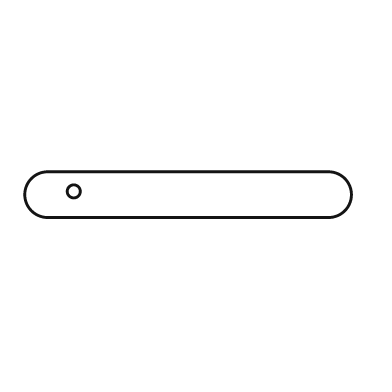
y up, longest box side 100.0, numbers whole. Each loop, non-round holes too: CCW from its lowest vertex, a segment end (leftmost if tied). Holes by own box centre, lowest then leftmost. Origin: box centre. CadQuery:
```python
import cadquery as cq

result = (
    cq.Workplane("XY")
    .moveTo(-43.0, -7.0)
    .lineTo(43.0, -7.0)
    .threePointArc((50.0, 0.0), (43.0, 7.0))
    .lineTo(-43.0, 7.0)
    .threePointArc((-50.0, 0.0), (-43.0, -7.0))
    .close()
    .moveTo(-35.0, 1.0)
    .circle(2.0)
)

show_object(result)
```